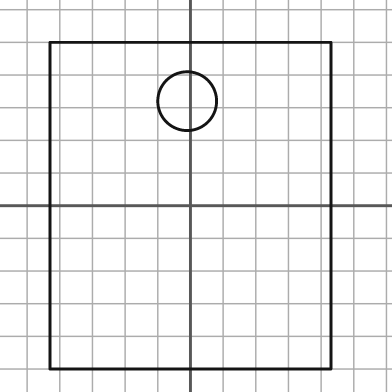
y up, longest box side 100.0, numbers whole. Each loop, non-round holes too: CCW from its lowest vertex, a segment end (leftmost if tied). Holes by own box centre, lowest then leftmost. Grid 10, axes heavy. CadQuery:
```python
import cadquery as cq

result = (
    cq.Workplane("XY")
    .moveTo(-43.0, -50.0)
    .lineTo(43.0, -50.0)
    .lineTo(43.0, 50.0)
    .lineTo(-43.0, 50.0)
    .close()
    .moveTo(-1.0, 32.0)
    .circle(9.0)
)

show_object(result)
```